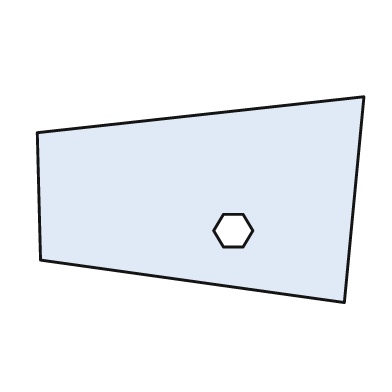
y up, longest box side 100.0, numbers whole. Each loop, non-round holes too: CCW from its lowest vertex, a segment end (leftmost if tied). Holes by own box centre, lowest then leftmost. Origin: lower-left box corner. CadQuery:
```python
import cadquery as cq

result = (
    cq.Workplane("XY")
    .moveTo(94.0, 0.0)
    .lineTo(100.0, 63.0)
    .lineTo(0.0, 52.0)
    .lineTo(1.0, 13.0)
    .close()
    .moveTo(57.0, 17.0)
    .lineTo(63.0, 17.0)
    .lineTo(66.0, 22.0)
    .lineTo(63.0, 27.0)
    .lineTo(57.0, 27.0)
    .lineTo(54.0, 22.0)
    .close()
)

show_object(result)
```